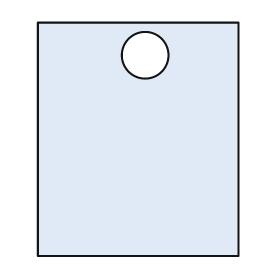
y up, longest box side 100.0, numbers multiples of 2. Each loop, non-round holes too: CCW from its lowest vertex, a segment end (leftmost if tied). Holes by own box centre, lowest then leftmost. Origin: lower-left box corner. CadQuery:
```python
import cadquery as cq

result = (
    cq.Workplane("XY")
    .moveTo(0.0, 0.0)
    .lineTo(86.0, 0.0)
    .lineTo(86.0, 100.0)
    .lineTo(0.0, 100.0)
    .close()
    .moveTo(46.0, 86.0)
    .circle(10.0)
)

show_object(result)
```